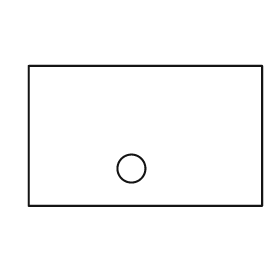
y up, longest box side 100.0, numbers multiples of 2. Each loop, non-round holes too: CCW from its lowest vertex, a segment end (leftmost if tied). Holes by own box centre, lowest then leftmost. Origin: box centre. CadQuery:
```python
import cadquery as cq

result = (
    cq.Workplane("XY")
    .moveTo(-50.0, -30.0)
    .lineTo(50.0, -30.0)
    .lineTo(50.0, 30.0)
    .lineTo(-50.0, 30.0)
    .close()
    .moveTo(-6.0, -14.0)
    .circle(6.0)
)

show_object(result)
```